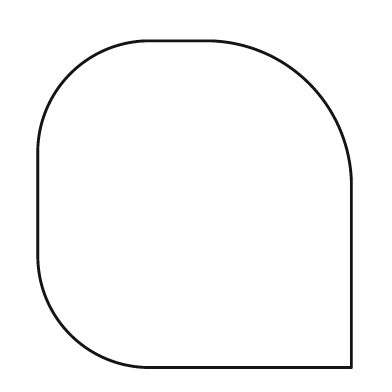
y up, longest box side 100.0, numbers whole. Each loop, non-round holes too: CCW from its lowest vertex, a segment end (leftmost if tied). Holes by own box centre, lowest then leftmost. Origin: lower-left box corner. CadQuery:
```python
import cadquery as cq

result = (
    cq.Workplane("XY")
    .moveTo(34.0, 0.0)
    .lineTo(96.0, 0.0)
    .lineTo(96.0, 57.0)
    .threePointArc((83.0, 87.0), (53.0, 100.0))
    .lineTo(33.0, 100.0)
    .threePointArc((10.0, 90.0), (0.0, 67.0))
    .lineTo(0.0, 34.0)
    .threePointArc((10.0, 10.0), (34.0, 0.0))
    .close()
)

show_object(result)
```